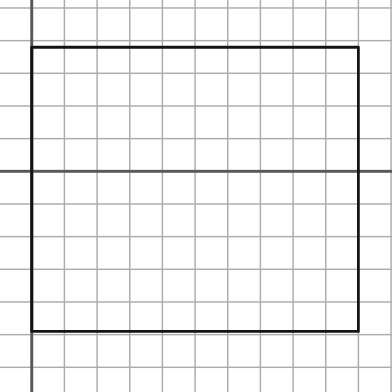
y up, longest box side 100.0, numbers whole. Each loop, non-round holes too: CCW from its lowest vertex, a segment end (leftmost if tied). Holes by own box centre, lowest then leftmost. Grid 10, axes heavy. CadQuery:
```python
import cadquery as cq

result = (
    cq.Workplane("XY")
    .moveTo(0.0, -49.0)
    .lineTo(100.0, -49.0)
    .lineTo(100.0, 38.0)
    .lineTo(0.0, 38.0)
    .close()
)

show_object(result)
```